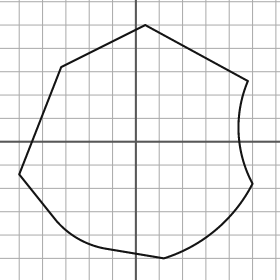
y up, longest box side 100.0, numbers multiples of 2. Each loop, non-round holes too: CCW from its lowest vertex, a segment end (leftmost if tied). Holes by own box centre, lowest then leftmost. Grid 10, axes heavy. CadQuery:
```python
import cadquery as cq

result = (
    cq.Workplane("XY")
    .moveTo(12.0, -50.0)
    .threePointArc((34.0, -38.0), (50.0, -18.0))
    .threePointArc((44.0, 4.0), (48.0, 26.0))
    .lineTo(4.0, 50.0)
    .lineTo(-32.0, 32.0)
    .lineTo(-50.0, -14.0)
    .lineTo(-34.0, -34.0)
    .threePointArc((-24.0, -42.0), (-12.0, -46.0))
    .close()
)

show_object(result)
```